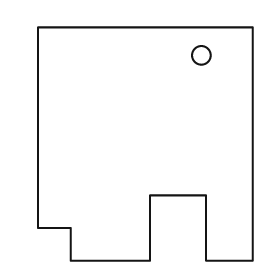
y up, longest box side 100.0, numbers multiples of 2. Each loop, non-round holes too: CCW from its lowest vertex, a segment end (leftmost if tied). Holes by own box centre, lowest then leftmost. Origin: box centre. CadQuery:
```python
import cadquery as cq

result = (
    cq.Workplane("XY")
    .moveTo(-32.0, -50.0)
    .lineTo(2.0, -50.0)
    .lineTo(2.0, -22.0)
    .lineTo(26.0, -22.0)
    .lineTo(26.0, -50.0)
    .lineTo(46.0, -50.0)
    .lineTo(46.0, 50.0)
    .lineTo(-46.0, 50.0)
    .lineTo(-46.0, -36.0)
    .lineTo(-32.0, -36.0)
    .close()
    .moveTo(24.0, 38.0)
    .circle(4.0)
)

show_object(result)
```